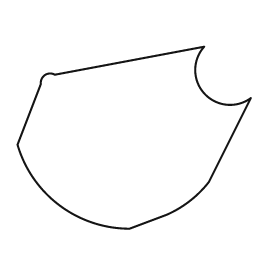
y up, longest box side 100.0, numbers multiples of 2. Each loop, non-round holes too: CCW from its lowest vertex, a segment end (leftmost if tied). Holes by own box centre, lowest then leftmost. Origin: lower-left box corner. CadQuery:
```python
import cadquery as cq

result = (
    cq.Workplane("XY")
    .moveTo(48.0, 0.0)
    .lineTo(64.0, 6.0)
    .threePointArc((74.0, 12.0), (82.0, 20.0))
    .lineTo(100.0, 56.0)
    .threePointArc((80.0, 58.0), (80.0, 78.0))
    .lineTo(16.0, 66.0)
    .threePointArc((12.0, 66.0), (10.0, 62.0))
    .lineTo(0.0, 36.0)
    .threePointArc((18.0, 10.0), (48.0, 0.0))
    .close()
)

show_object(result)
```